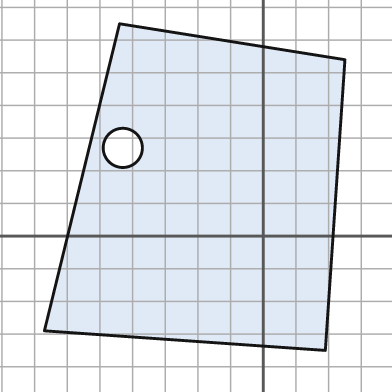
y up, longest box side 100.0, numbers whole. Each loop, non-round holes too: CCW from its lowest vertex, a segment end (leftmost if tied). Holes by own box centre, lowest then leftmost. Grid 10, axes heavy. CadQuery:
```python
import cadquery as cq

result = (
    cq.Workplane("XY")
    .moveTo(19.0, -35.0)
    .lineTo(25.0, 54.0)
    .lineTo(-44.0, 65.0)
    .lineTo(-67.0, -29.0)
    .close()
    .moveTo(-43.0, 27.0)
    .circle(6.0)
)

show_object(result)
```